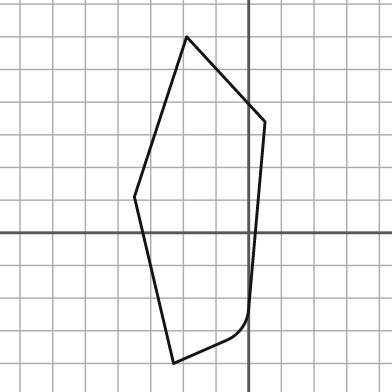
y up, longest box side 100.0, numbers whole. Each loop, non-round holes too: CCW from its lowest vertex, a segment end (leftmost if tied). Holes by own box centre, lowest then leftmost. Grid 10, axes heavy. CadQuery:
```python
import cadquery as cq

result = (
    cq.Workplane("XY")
    .moveTo(-23.0, -40.0)
    .lineTo(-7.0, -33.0)
    .threePointArc((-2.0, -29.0), (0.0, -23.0))
    .lineTo(5.0, 34.0)
    .lineTo(-19.0, 60.0)
    .lineTo(-35.0, 11.0)
    .close()
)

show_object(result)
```